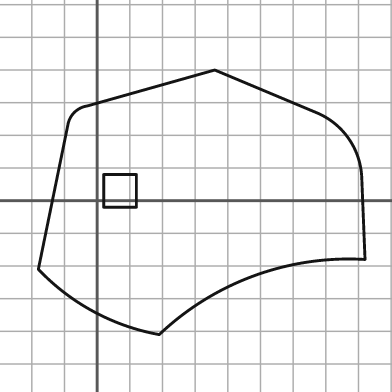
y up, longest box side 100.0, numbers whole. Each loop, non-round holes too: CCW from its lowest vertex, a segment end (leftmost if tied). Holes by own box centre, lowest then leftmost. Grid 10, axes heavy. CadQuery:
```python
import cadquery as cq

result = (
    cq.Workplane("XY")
    .moveTo(19.0, -41.0)
    .threePointArc((48.0, -23.0), (82.0, -18.0))
    .lineTo(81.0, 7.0)
    .threePointArc((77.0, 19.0), (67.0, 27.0))
    .lineTo(36.0, 40.0)
    .lineTo(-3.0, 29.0)
    .threePointArc((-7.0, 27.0), (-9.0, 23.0))
    .lineTo(-18.0, -21.0)
    .threePointArc((-1.0, -34.0), (19.0, -41.0))
    .close()
    .moveTo(2.0, -2.0)
    .lineTo(12.0, -2.0)
    .lineTo(12.0, 8.0)
    .lineTo(2.0, 8.0)
    .close()
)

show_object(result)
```